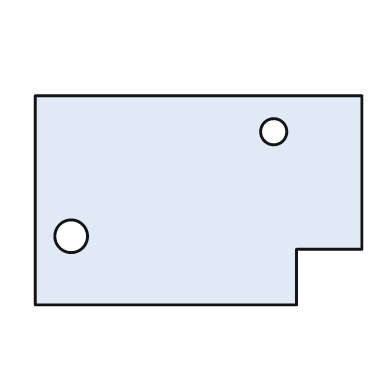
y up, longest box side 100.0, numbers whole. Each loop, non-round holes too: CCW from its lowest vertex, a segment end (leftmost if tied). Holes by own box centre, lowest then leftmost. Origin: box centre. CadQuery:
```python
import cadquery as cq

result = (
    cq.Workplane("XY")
    .moveTo(-50.0, -32.0)
    .lineTo(30.0, -32.0)
    .lineTo(30.0, -15.0)
    .lineTo(50.0, -15.0)
    .lineTo(50.0, 32.0)
    .lineTo(-50.0, 32.0)
    .close()
    .moveTo(-39.0, -11.0)
    .circle(5.0)
    .moveTo(23.0, 21.0)
    .circle(4.0)
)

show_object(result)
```